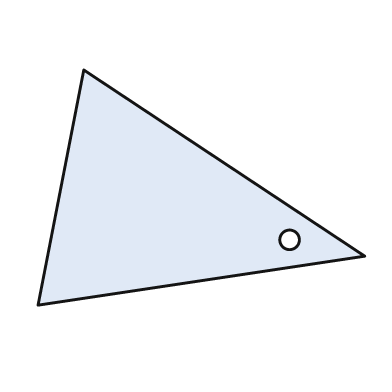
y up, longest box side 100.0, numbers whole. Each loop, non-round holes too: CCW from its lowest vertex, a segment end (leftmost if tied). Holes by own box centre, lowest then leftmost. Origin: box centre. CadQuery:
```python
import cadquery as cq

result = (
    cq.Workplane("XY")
    .moveTo(-50.0, -36.0)
    .lineTo(50.0, -21.0)
    .lineTo(-36.0, 36.0)
    .close()
    .moveTo(27.0, -16.0)
    .circle(3.0)
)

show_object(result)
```